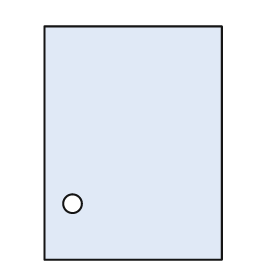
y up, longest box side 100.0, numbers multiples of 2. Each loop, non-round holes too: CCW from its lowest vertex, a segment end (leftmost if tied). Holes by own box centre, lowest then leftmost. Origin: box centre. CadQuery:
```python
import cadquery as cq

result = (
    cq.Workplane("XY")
    .moveTo(-38.0, -50.0)
    .lineTo(38.0, -50.0)
    .lineTo(38.0, 50.0)
    .lineTo(-38.0, 50.0)
    .close()
    .moveTo(-26.0, -26.0)
    .circle(4.0)
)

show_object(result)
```